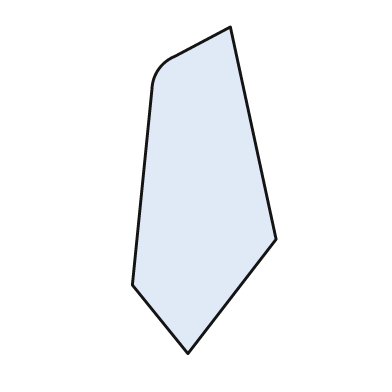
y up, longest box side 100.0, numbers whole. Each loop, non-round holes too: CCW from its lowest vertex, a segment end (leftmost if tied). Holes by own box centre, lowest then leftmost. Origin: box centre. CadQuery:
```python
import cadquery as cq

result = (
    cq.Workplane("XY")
    .moveTo(-5.0, -50.0)
    .lineTo(22.0, -15.0)
    .lineTo(8.0, 50.0)
    .lineTo(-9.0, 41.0)
    .threePointArc((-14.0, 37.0), (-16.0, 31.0))
    .lineTo(-22.0, -29.0)
    .close()
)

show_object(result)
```